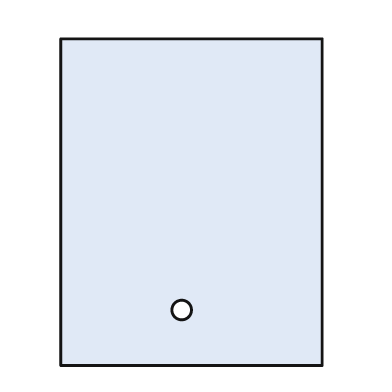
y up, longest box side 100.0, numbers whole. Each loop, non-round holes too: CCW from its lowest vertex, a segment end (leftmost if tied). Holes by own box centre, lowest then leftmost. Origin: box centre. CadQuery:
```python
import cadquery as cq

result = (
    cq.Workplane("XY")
    .moveTo(-40.0, -50.0)
    .lineTo(40.0, -50.0)
    .lineTo(40.0, 50.0)
    .lineTo(-40.0, 50.0)
    .close()
    .moveTo(-3.0, -33.0)
    .circle(3.0)
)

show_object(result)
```